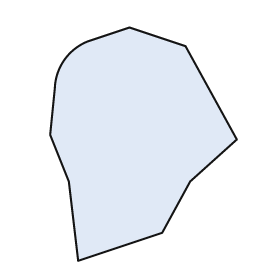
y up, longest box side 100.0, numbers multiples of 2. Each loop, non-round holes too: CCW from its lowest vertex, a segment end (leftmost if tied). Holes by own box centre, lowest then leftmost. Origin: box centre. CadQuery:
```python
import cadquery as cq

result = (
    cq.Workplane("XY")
    .moveTo(-28.0, -50.0)
    .lineTo(8.0, -38.0)
    .lineTo(20.0, -16.0)
    .lineTo(40.0, 2.0)
    .lineTo(18.0, 42.0)
    .lineTo(-6.0, 50.0)
    .lineTo(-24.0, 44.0)
    .threePointArc((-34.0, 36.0), (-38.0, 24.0))
    .lineTo(-40.0, 4.0)
    .lineTo(-32.0, -16.0)
    .close()
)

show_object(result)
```